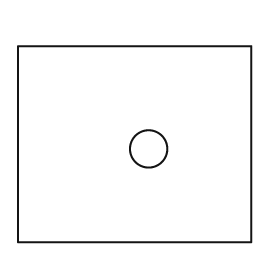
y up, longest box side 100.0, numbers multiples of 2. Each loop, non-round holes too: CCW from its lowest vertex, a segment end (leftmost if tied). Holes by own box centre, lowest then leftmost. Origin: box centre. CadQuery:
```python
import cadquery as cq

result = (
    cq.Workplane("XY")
    .moveTo(-50.0, -42.0)
    .lineTo(50.0, -42.0)
    .lineTo(50.0, 42.0)
    .lineTo(-50.0, 42.0)
    .close()
    .moveTo(6.0, -2.0)
    .circle(8.0)
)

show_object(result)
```